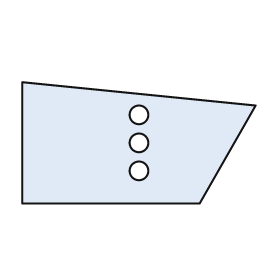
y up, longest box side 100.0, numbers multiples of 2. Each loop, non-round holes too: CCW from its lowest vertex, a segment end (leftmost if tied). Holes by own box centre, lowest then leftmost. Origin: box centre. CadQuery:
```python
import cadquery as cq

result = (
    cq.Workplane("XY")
    .moveTo(-50.0, -26.0)
    .lineTo(26.0, -26.0)
    .lineTo(50.0, 16.0)
    .lineTo(-50.0, 26.0)
    .close()
    .moveTo(0.0, -12.0)
    .circle(4.0)
    .moveTo(0.0, 0.0)
    .circle(4.0)
    .moveTo(0.0, 12.0)
    .circle(4.0)
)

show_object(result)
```